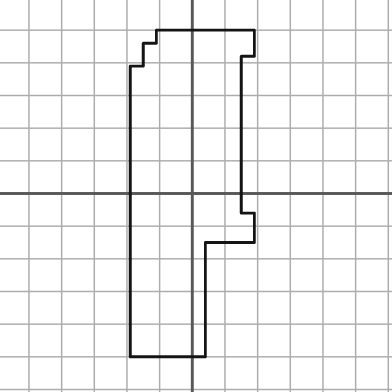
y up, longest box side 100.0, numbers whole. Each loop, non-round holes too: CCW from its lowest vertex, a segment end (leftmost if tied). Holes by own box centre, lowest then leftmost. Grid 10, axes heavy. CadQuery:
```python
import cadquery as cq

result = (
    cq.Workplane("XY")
    .moveTo(-19.0, -50.0)
    .lineTo(4.0, -50.0)
    .lineTo(4.0, -15.0)
    .lineTo(19.0, -15.0)
    .lineTo(19.0, -6.0)
    .lineTo(15.0, -6.0)
    .lineTo(15.0, 42.0)
    .lineTo(19.0, 42.0)
    .lineTo(19.0, 50.0)
    .lineTo(-11.0, 50.0)
    .lineTo(-11.0, 46.0)
    .lineTo(-15.0, 46.0)
    .lineTo(-15.0, 39.0)
    .lineTo(-19.0, 39.0)
    .close()
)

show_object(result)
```